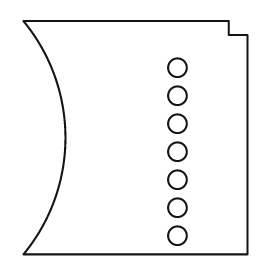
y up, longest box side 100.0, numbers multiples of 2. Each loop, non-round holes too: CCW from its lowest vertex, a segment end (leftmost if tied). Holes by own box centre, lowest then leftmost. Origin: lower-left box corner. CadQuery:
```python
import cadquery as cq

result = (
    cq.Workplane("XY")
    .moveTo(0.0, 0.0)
    .lineTo(96.0, 0.0)
    .lineTo(96.0, 94.0)
    .lineTo(88.0, 94.0)
    .lineTo(88.0, 100.0)
    .lineTo(0.0, 100.0)
    .threePointArc((18.0, 50.0), (0.0, 0.0))
    .close()
    .moveTo(66.0, 8.0)
    .circle(4.0)
    .moveTo(66.0, 20.0)
    .circle(4.0)
    .moveTo(66.0, 32.0)
    .circle(4.0)
    .moveTo(66.0, 44.0)
    .circle(4.0)
    .moveTo(66.0, 56.0)
    .circle(4.0)
    .moveTo(66.0, 68.0)
    .circle(4.0)
    .moveTo(66.0, 80.0)
    .circle(4.0)
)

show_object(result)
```